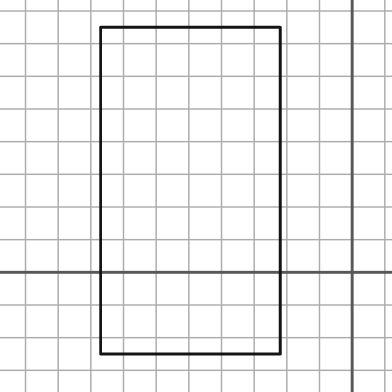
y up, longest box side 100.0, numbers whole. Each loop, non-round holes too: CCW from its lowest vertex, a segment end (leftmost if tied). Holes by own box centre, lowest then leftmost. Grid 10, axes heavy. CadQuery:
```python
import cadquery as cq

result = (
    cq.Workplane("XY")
    .moveTo(-77.0, -25.0)
    .lineTo(-22.0, -25.0)
    .lineTo(-22.0, 75.0)
    .lineTo(-77.0, 75.0)
    .close()
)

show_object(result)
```